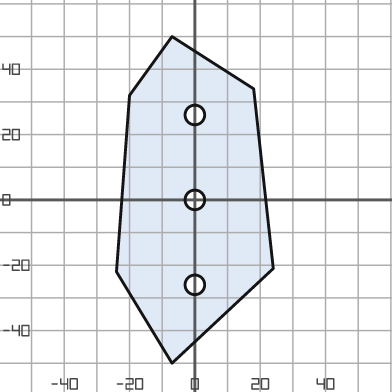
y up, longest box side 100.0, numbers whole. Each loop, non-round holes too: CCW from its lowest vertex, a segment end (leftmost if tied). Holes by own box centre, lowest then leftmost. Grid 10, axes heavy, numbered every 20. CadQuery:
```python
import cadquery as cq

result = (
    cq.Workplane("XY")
    .moveTo(-7.0, -50.0)
    .lineTo(24.0, -21.0)
    .lineTo(18.0, 34.0)
    .lineTo(-7.0, 50.0)
    .lineTo(-20.0, 32.0)
    .lineTo(-24.0, -22.0)
    .close()
    .moveTo(0.0, -26.0)
    .circle(3.0)
    .moveTo(0.0, 0.0)
    .circle(3.0)
    .moveTo(0.0, 26.0)
    .circle(3.0)
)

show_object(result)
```